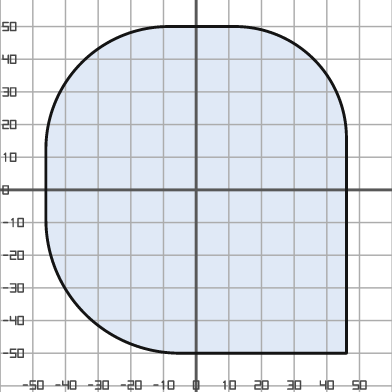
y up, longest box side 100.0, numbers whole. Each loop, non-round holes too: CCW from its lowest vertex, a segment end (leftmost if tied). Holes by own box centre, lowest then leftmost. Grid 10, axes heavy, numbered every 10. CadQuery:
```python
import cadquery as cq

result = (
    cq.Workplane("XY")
    .moveTo(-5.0, -50.0)
    .lineTo(46.0, -50.0)
    .lineTo(46.0, 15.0)
    .threePointArc((36.0, 40.0), (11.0, 50.0))
    .lineTo(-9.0, 50.0)
    .threePointArc((-35.0, 39.0), (-46.0, 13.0))
    .lineTo(-46.0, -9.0)
    .threePointArc((-34.0, -38.0), (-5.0, -50.0))
    .close()
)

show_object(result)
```